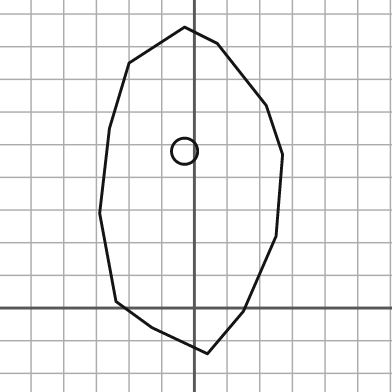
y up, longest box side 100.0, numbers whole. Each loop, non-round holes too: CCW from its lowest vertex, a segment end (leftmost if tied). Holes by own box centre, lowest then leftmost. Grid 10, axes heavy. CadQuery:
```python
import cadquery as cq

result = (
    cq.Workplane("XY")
    .moveTo(4.0, -14.0)
    .lineTo(15.0, -1.0)
    .lineTo(25.0, 22.0)
    .lineTo(27.0, 47.0)
    .lineTo(22.0, 62.0)
    .lineTo(7.0, 81.0)
    .lineTo(-3.0, 86.0)
    .lineTo(-20.0, 75.0)
    .lineTo(-26.0, 55.0)
    .lineTo(-29.0, 29.0)
    .lineTo(-24.0, 2.0)
    .lineTo(-13.0, -6.0)
    .close()
    .moveTo(-3.0, 48.0)
    .circle(4.0)
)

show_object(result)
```